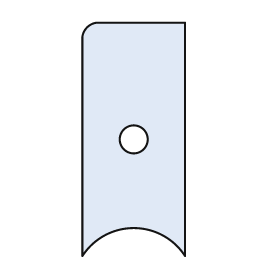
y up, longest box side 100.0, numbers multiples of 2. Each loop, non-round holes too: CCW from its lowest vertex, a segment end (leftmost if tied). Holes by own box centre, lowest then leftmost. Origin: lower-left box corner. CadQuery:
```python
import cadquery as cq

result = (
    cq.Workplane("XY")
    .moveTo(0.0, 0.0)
    .threePointArc((22.0, 12.0), (44.0, 0.0))
    .lineTo(44.0, 100.0)
    .lineTo(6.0, 100.0)
    .threePointArc((2.0, 98.0), (0.0, 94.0))
    .close()
    .moveTo(22.0, 50.0)
    .circle(6.0)
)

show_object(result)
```